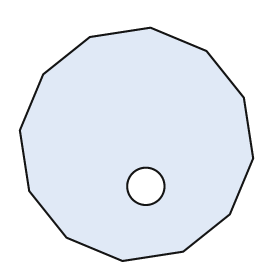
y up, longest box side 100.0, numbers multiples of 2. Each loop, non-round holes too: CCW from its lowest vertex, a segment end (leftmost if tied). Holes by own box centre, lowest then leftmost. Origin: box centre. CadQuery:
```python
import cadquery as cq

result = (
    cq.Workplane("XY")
    .moveTo(-6.0, -50.0)
    .lineTo(20.0, -46.0)
    .lineTo(40.0, -30.0)
    .lineTo(50.0, -6.0)
    .lineTo(46.0, 20.0)
    .lineTo(30.0, 40.0)
    .lineTo(6.0, 50.0)
    .lineTo(-20.0, 46.0)
    .lineTo(-40.0, 30.0)
    .lineTo(-50.0, 6.0)
    .lineTo(-46.0, -20.0)
    .lineTo(-30.0, -40.0)
    .close()
    .moveTo(4.0, -18.0)
    .circle(8.0)
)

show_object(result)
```